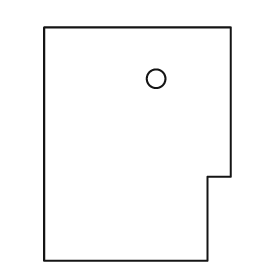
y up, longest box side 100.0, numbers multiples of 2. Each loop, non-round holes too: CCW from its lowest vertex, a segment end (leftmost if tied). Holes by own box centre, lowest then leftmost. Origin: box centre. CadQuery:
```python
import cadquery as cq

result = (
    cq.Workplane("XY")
    .moveTo(-40.0, -50.0)
    .lineTo(30.0, -50.0)
    .lineTo(30.0, -14.0)
    .lineTo(40.0, -14.0)
    .lineTo(40.0, 50.0)
    .lineTo(-40.0, 50.0)
    .close()
    .moveTo(8.0, 28.0)
    .circle(4.0)
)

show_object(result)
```